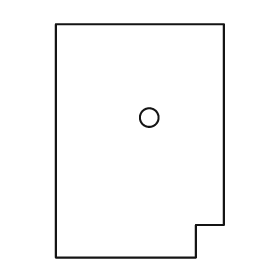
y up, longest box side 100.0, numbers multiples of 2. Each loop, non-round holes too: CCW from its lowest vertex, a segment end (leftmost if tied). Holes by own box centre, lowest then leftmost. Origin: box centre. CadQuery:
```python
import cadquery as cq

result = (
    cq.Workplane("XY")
    .moveTo(-36.0, -50.0)
    .lineTo(24.0, -50.0)
    .lineTo(24.0, -36.0)
    .lineTo(36.0, -36.0)
    .lineTo(36.0, 50.0)
    .lineTo(-36.0, 50.0)
    .close()
    .moveTo(4.0, 10.0)
    .circle(4.0)
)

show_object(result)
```